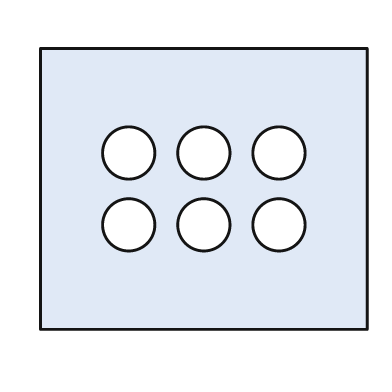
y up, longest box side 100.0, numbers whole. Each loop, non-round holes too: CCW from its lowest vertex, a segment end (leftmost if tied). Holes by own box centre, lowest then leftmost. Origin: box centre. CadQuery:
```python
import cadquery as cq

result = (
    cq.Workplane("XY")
    .moveTo(-50.0, -43.0)
    .lineTo(50.0, -43.0)
    .lineTo(50.0, 43.0)
    .lineTo(-50.0, 43.0)
    .close()
    .moveTo(-23.0, -11.0)
    .circle(8.0)
    .moveTo(0.0, -11.0)
    .circle(8.0)
    .moveTo(23.0, -11.0)
    .circle(8.0)
    .moveTo(-23.0, 11.0)
    .circle(8.0)
    .moveTo(0.0, 11.0)
    .circle(8.0)
    .moveTo(23.0, 11.0)
    .circle(8.0)
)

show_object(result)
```